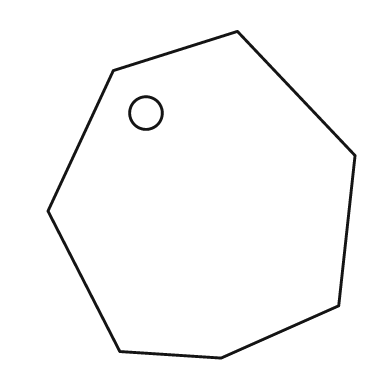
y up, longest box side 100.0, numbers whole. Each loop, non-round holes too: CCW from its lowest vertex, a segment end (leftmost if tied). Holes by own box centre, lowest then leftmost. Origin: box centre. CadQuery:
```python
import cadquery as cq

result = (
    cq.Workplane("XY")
    .moveTo(6.0, -50.0)
    .lineTo(42.0, -34.0)
    .lineTo(47.0, 12.0)
    .lineTo(11.0, 50.0)
    .lineTo(-27.0, 38.0)
    .lineTo(-47.0, -5.0)
    .lineTo(-25.0, -48.0)
    .close()
    .moveTo(-17.0, 25.0)
    .circle(5.0)
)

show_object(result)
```